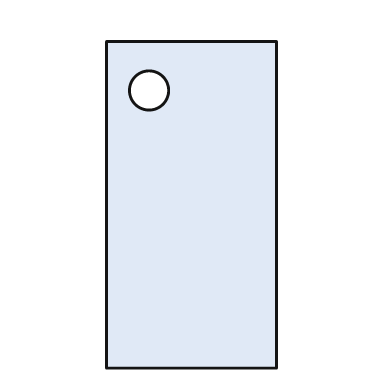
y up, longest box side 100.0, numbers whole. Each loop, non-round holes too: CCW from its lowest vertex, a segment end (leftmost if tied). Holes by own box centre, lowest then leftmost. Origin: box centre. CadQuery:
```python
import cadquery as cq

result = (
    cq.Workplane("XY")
    .moveTo(-26.0, -50.0)
    .lineTo(26.0, -50.0)
    .lineTo(26.0, 50.0)
    .lineTo(-26.0, 50.0)
    .close()
    .moveTo(-13.0, 35.0)
    .circle(6.0)
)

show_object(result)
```